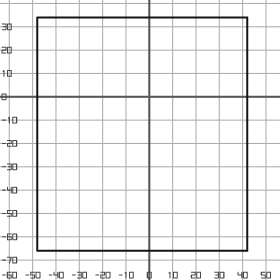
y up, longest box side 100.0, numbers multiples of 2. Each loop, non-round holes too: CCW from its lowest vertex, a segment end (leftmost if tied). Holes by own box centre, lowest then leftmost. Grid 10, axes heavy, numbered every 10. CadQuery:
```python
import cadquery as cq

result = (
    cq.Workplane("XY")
    .moveTo(-48.0, -66.0)
    .lineTo(42.0, -66.0)
    .lineTo(42.0, 34.0)
    .lineTo(-48.0, 34.0)
    .close()
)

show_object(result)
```